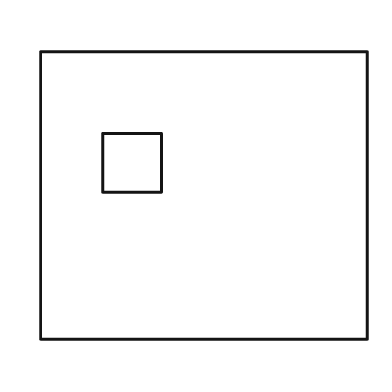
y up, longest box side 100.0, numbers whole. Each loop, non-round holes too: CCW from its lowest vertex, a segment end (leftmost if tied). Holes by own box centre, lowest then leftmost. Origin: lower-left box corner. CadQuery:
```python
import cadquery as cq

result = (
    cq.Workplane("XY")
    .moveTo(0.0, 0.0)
    .lineTo(100.0, 0.0)
    .lineTo(100.0, 88.0)
    .lineTo(0.0, 88.0)
    .close()
    .moveTo(19.0, 45.0)
    .lineTo(37.0, 45.0)
    .lineTo(37.0, 63.0)
    .lineTo(19.0, 63.0)
    .close()
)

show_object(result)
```